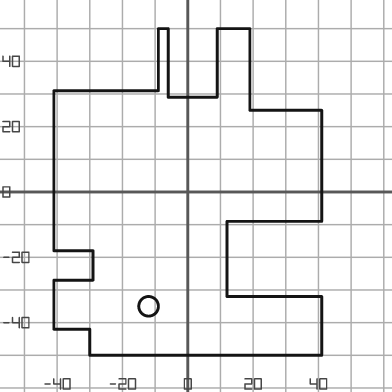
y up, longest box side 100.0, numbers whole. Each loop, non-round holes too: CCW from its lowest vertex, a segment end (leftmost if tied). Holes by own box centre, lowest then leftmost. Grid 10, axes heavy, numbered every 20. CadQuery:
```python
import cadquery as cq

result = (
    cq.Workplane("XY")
    .moveTo(-30.0, -50.0)
    .lineTo(41.0, -50.0)
    .lineTo(41.0, -32.0)
    .lineTo(12.0, -32.0)
    .lineTo(12.0, -9.0)
    .lineTo(41.0, -9.0)
    .lineTo(41.0, 25.0)
    .lineTo(19.0, 25.0)
    .lineTo(19.0, 50.0)
    .lineTo(9.0, 50.0)
    .lineTo(9.0, 29.0)
    .lineTo(-6.0, 29.0)
    .lineTo(-6.0, 50.0)
    .lineTo(-9.0, 50.0)
    .lineTo(-9.0, 31.0)
    .lineTo(-41.0, 31.0)
    .lineTo(-41.0, -18.0)
    .lineTo(-29.0, -18.0)
    .lineTo(-29.0, -27.0)
    .lineTo(-41.0, -27.0)
    .lineTo(-41.0, -42.0)
    .lineTo(-30.0, -42.0)
    .close()
    .moveTo(-12.0, -35.0)
    .circle(3.0)
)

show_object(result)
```